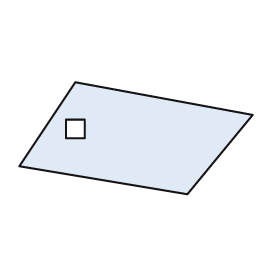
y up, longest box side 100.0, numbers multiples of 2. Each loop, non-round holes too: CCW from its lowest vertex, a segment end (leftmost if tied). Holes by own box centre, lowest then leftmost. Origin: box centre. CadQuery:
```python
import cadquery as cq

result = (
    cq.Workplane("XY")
    .moveTo(22.0, -24.0)
    .lineTo(50.0, 10.0)
    .lineTo(-26.0, 24.0)
    .lineTo(-50.0, -12.0)
    .close()
    .moveTo(-30.0, 0.0)
    .lineTo(-22.0, 0.0)
    .lineTo(-22.0, 8.0)
    .lineTo(-30.0, 8.0)
    .close()
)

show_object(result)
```